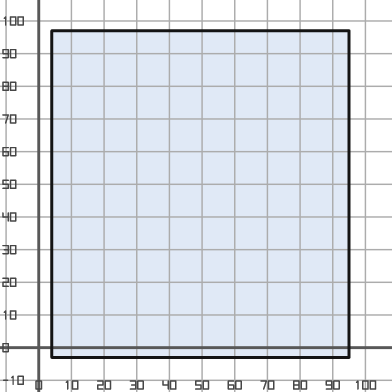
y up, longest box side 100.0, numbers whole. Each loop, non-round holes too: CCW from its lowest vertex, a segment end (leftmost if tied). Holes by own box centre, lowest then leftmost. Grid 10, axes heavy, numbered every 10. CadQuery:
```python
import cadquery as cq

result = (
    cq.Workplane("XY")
    .moveTo(4.0, -3.0)
    .lineTo(95.0, -3.0)
    .lineTo(95.0, 97.0)
    .lineTo(4.0, 97.0)
    .close()
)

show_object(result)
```